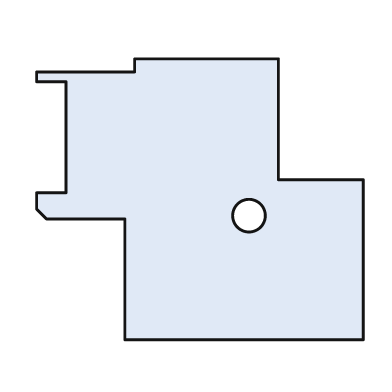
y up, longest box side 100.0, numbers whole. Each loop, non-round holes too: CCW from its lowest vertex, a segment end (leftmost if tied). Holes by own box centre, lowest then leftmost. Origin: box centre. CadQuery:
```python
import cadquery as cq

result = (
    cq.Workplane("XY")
    .moveTo(-23.0, -43.0)
    .lineTo(50.0, -43.0)
    .lineTo(50.0, 6.0)
    .lineTo(24.0, 6.0)
    .lineTo(24.0, 43.0)
    .lineTo(-20.0, 43.0)
    .lineTo(-20.0, 39.0)
    .lineTo(-50.0, 39.0)
    .lineTo(-50.0, 36.0)
    .lineTo(-41.0, 36.0)
    .lineTo(-41.0, 2.0)
    .lineTo(-50.0, 2.0)
    .lineTo(-50.0, -3.0)
    .lineTo(-47.0, -6.0)
    .lineTo(-23.0, -6.0)
    .close()
    .moveTo(15.0, -5.0)
    .circle(5.0)
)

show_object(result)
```